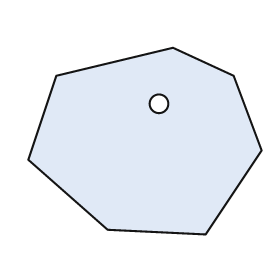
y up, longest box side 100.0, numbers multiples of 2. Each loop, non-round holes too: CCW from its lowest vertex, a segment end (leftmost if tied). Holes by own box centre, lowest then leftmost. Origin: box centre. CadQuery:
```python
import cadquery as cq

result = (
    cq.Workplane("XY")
    .moveTo(26.0, -40.0)
    .lineTo(50.0, -4.0)
    .lineTo(38.0, 28.0)
    .lineTo(12.0, 40.0)
    .lineTo(-38.0, 28.0)
    .lineTo(-50.0, -8.0)
    .lineTo(-16.0, -38.0)
    .close()
    .moveTo(6.0, 16.0)
    .circle(4.0)
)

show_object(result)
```